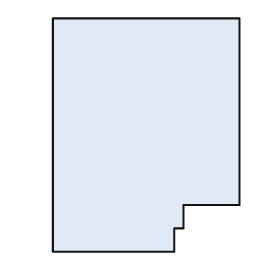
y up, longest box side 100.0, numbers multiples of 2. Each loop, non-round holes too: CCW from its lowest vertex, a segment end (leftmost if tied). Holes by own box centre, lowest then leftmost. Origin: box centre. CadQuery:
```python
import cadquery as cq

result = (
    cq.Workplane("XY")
    .moveTo(-40.0, -50.0)
    .lineTo(12.0, -50.0)
    .lineTo(12.0, -40.0)
    .lineTo(16.0, -40.0)
    .lineTo(16.0, -30.0)
    .lineTo(40.0, -30.0)
    .lineTo(40.0, 50.0)
    .lineTo(-40.0, 50.0)
    .close()
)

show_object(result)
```